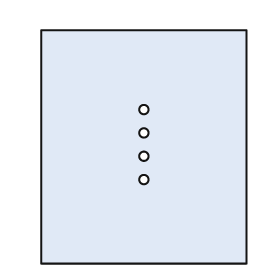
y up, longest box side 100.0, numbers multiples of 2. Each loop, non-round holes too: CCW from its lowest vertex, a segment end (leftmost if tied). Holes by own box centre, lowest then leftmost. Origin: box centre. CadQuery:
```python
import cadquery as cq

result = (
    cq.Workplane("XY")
    .moveTo(-44.0, -50.0)
    .lineTo(44.0, -50.0)
    .lineTo(44.0, 50.0)
    .lineTo(-44.0, 50.0)
    .close()
    .moveTo(0.0, -14.0)
    .circle(2.0)
    .moveTo(0.0, -4.0)
    .circle(2.0)
    .moveTo(0.0, 6.0)
    .circle(2.0)
    .moveTo(0.0, 16.0)
    .circle(2.0)
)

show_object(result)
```